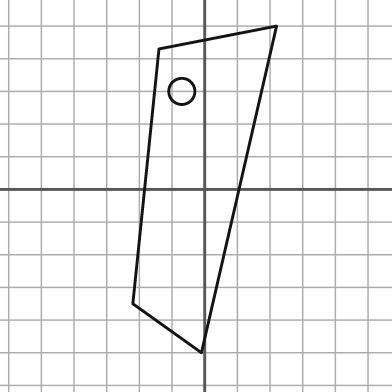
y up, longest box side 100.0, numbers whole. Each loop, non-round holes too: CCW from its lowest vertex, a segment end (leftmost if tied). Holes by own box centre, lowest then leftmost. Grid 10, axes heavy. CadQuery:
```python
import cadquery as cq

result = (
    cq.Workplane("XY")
    .moveTo(-1.0, -50.0)
    .lineTo(22.0, 50.0)
    .lineTo(-14.0, 43.0)
    .lineTo(-22.0, -35.0)
    .close()
    .moveTo(-7.0, 30.0)
    .circle(4.0)
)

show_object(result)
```